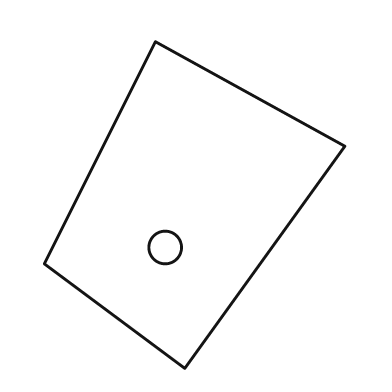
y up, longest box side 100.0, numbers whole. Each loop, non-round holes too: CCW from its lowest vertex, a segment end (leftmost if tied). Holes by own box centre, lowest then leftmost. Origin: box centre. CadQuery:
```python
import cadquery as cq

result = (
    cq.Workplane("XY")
    .moveTo(-3.0, -50.0)
    .lineTo(46.0, 18.0)
    .lineTo(-12.0, 50.0)
    .lineTo(-46.0, -18.0)
    .close()
    .moveTo(-9.0, -13.0)
    .circle(5.0)
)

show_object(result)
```